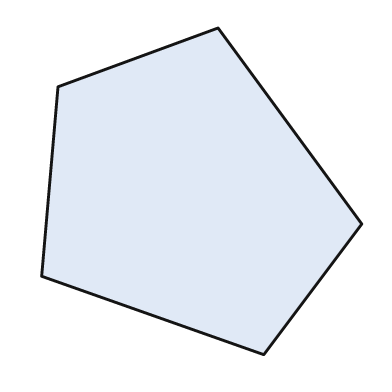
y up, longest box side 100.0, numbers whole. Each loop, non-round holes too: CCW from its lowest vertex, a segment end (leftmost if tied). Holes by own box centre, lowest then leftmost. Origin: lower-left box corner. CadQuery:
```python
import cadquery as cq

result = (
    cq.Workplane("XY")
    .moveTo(68.0, 0.0)
    .lineTo(98.0, 40.0)
    .lineTo(54.0, 100.0)
    .lineTo(5.0, 82.0)
    .lineTo(0.0, 24.0)
    .close()
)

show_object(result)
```